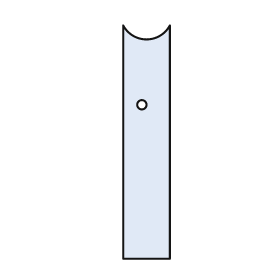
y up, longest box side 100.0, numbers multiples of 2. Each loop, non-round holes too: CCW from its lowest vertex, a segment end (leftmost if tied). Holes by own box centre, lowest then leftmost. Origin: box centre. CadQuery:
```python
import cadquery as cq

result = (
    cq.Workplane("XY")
    .moveTo(-10.0, -50.0)
    .lineTo(10.0, -50.0)
    .lineTo(10.0, 50.0)
    .threePointArc((0.0, 44.0), (-10.0, 50.0))
    .close()
    .moveTo(-2.0, 16.0)
    .circle(2.0)
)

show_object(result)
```